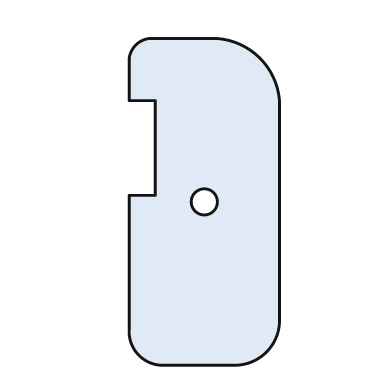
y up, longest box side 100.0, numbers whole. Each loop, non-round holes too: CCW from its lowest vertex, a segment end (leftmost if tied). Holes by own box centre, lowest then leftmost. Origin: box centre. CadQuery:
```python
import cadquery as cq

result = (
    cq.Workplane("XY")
    .moveTo(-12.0, -50.0)
    .lineTo(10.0, -50.0)
    .threePointArc((19.0, -46.0), (23.0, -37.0))
    .lineTo(23.0, 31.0)
    .threePointArc((17.0, 44.0), (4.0, 50.0))
    .lineTo(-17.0, 50.0)
    .threePointArc((-21.0, 48.0), (-23.0, 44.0))
    .lineTo(-23.0, 31.0)
    .lineTo(-15.0, 31.0)
    .lineTo(-15.0, 2.0)
    .lineTo(-23.0, 2.0)
    .lineTo(-23.0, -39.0)
    .threePointArc((-20.0, -47.0), (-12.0, -50.0))
    .close()
    .moveTo(0.0, 0.0)
    .circle(4.0)
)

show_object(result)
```